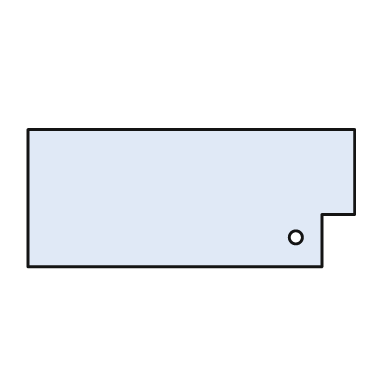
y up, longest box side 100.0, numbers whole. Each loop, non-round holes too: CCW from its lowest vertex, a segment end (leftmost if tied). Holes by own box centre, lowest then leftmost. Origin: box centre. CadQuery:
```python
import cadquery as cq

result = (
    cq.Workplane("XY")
    .moveTo(-50.0, -21.0)
    .lineTo(40.0, -21.0)
    .lineTo(40.0, -5.0)
    .lineTo(50.0, -5.0)
    .lineTo(50.0, 21.0)
    .lineTo(-50.0, 21.0)
    .close()
    .moveTo(32.0, -12.0)
    .circle(2.0)
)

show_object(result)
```